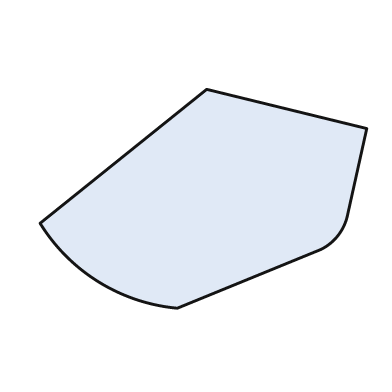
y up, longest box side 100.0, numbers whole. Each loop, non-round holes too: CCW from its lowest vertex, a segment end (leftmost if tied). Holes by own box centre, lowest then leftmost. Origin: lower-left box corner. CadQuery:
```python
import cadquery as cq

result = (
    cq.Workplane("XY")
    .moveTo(42.0, 0.0)
    .lineTo(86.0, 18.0)
    .threePointArc((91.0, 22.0), (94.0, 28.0))
    .lineTo(100.0, 55.0)
    .lineTo(51.0, 67.0)
    .lineTo(0.0, 26.0)
    .threePointArc((18.0, 8.0), (42.0, 0.0))
    .close()
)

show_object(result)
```